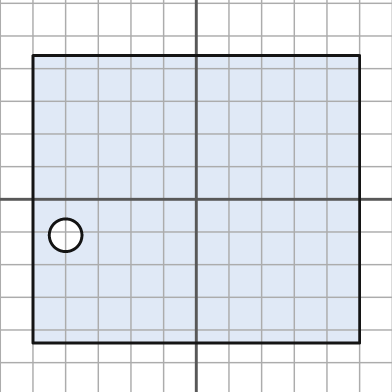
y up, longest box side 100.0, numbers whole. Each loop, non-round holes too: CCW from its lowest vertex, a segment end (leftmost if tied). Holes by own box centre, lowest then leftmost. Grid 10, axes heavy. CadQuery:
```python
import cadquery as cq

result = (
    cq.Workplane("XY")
    .moveTo(-50.0, -44.0)
    .lineTo(50.0, -44.0)
    .lineTo(50.0, 44.0)
    .lineTo(-50.0, 44.0)
    .close()
    .moveTo(-40.0, -11.0)
    .circle(5.0)
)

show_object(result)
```